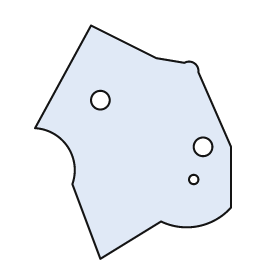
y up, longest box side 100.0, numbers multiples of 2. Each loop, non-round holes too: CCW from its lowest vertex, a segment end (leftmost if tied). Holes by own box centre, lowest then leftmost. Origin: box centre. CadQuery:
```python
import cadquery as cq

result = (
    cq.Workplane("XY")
    .moveTo(-14.0, -50.0)
    .lineTo(12.0, -34.0)
    .threePointArc((28.0, -36.0), (42.0, -28.0))
    .lineTo(42.0, -2.0)
    .lineTo(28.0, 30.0)
    .threePointArc((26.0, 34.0), (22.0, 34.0))
    .lineTo(10.0, 36.0)
    .lineTo(-18.0, 50.0)
    .lineTo(-42.0, 6.0)
    .threePointArc((-28.0, -2.0), (-26.0, -18.0))
    .close()
    .moveTo(26.0, -16.0)
    .circle(2.0)
    .moveTo(30.0, -2.0)
    .circle(4.0)
    .moveTo(-14.0, 18.0)
    .circle(4.0)
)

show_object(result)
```